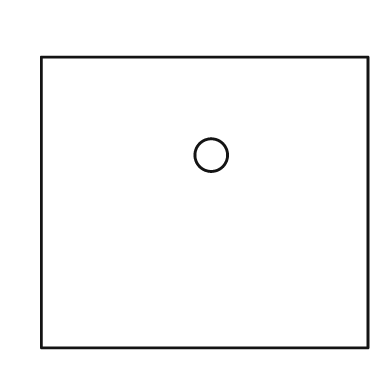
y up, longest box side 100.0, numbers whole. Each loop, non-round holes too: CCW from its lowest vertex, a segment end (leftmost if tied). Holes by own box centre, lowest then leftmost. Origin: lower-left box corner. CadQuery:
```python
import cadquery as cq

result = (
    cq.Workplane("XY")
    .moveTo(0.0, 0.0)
    .lineTo(100.0, 0.0)
    .lineTo(100.0, 89.0)
    .lineTo(0.0, 89.0)
    .close()
    .moveTo(52.0, 59.0)
    .circle(5.0)
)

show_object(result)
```